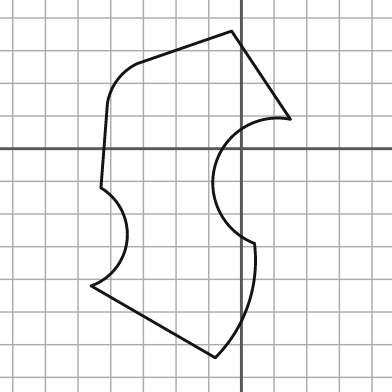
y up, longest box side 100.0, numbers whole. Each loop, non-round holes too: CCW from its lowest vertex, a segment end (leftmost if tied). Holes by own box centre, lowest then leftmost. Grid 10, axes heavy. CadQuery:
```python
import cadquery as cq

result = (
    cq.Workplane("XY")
    .moveTo(-8.0, -64.0)
    .threePointArc((2.0, -48.0), (4.0, -29.0))
    .threePointArc((-8.0, -5.0), (15.0, 9.0))
    .lineTo(-3.0, 36.0)
    .lineTo(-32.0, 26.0)
    .threePointArc((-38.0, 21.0), (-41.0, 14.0))
    .lineTo(-43.0, -12.0)
    .threePointArc((-35.0, -28.0), (-46.0, -42.0))
    .close()
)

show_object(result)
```